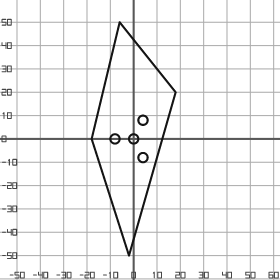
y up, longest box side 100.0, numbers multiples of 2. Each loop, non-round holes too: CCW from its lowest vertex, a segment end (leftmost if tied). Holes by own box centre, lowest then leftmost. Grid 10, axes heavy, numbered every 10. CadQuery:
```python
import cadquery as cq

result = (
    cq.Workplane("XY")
    .moveTo(-2.0, -50.0)
    .lineTo(18.0, 20.0)
    .lineTo(-6.0, 50.0)
    .lineTo(-18.0, 0.0)
    .close()
    .moveTo(4.0, -8.0)
    .circle(2.0)
    .moveTo(-8.0, 0.0)
    .circle(2.0)
    .moveTo(0.0, 0.0)
    .circle(2.0)
    .moveTo(4.0, 8.0)
    .circle(2.0)
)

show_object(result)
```